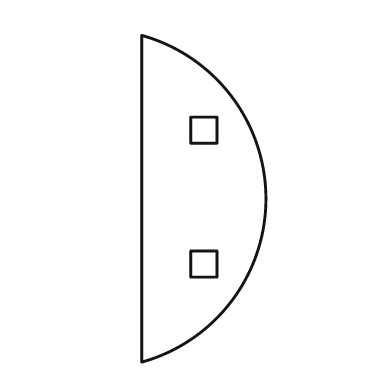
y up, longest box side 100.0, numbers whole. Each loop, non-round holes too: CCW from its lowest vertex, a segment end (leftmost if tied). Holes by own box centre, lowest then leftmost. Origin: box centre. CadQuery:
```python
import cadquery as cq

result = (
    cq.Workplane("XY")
    .moveTo(-19.0, -50.0)
    .threePointArc((19.0, 0.0), (-19.0, 50.0))
    .close()
    .moveTo(-4.0, -24.0)
    .lineTo(4.0, -24.0)
    .lineTo(4.0, -16.0)
    .lineTo(-4.0, -16.0)
    .close()
    .moveTo(-4.0, 17.0)
    .lineTo(4.0, 17.0)
    .lineTo(4.0, 25.0)
    .lineTo(-4.0, 25.0)
    .close()
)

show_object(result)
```